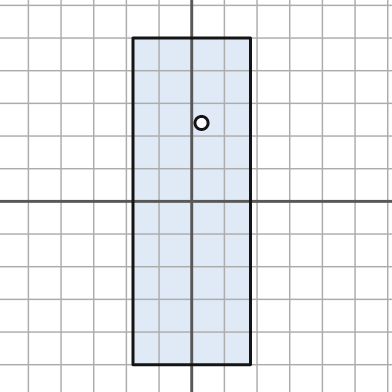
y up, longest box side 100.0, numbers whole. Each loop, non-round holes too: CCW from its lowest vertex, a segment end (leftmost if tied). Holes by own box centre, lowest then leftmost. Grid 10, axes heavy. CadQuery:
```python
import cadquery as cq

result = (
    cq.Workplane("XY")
    .moveTo(-18.0, -50.0)
    .lineTo(18.0, -50.0)
    .lineTo(18.0, 50.0)
    .lineTo(-18.0, 50.0)
    .close()
    .moveTo(3.0, 24.0)
    .circle(2.0)
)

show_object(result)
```